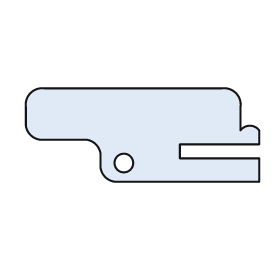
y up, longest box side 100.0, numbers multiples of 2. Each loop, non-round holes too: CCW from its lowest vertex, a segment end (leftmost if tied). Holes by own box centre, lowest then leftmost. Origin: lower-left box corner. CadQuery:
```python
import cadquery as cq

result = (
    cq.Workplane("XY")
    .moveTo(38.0, 0.0)
    .lineTo(100.0, 0.0)
    .lineTo(100.0, 10.0)
    .lineTo(66.0, 10.0)
    .lineTo(66.0, 16.0)
    .lineTo(100.0, 16.0)
    .lineTo(100.0, 22.0)
    .threePointArc((96.0, 24.0), (92.0, 22.0))
    .lineTo(92.0, 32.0)
    .threePointArc((90.0, 38.0), (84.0, 40.0))
    .lineTo(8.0, 40.0)
    .threePointArc((2.0, 38.0), (0.0, 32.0))
    .lineTo(0.0, 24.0)
    .threePointArc((2.0, 20.0), (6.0, 18.0))
    .lineTo(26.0, 18.0)
    .threePointArc((30.0, 16.0), (32.0, 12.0))
    .lineTo(32.0, 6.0)
    .threePointArc((34.0, 2.0), (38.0, 0.0))
    .close()
    .moveTo(42.0, 8.0)
    .circle(4.0)
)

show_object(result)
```